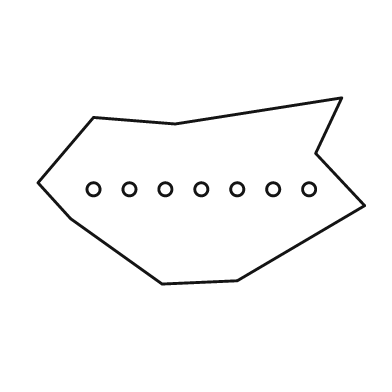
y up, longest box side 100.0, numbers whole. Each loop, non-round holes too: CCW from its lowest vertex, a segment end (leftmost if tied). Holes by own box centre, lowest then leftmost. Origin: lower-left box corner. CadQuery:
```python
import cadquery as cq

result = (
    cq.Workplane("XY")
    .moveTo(38.0, 0.0)
    .lineTo(61.0, 1.0)
    .lineTo(100.0, 24.0)
    .lineTo(85.0, 40.0)
    .lineTo(93.0, 57.0)
    .lineTo(42.0, 49.0)
    .lineTo(17.0, 51.0)
    .lineTo(0.0, 31.0)
    .lineTo(10.0, 20.0)
    .close()
    .moveTo(17.0, 29.0)
    .circle(2.0)
    .moveTo(28.0, 29.0)
    .circle(2.0)
    .moveTo(39.0, 29.0)
    .circle(2.0)
    .moveTo(50.0, 29.0)
    .circle(2.0)
    .moveTo(61.0, 29.0)
    .circle(2.0)
    .moveTo(72.0, 29.0)
    .circle(2.0)
    .moveTo(83.0, 29.0)
    .circle(2.0)
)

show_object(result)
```